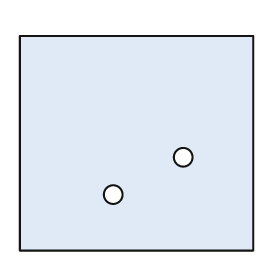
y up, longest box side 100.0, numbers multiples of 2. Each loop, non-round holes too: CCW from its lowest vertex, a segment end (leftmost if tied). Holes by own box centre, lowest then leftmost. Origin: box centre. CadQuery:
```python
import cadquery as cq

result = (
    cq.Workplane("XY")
    .moveTo(-50.0, -46.0)
    .lineTo(50.0, -46.0)
    .lineTo(50.0, 46.0)
    .lineTo(-50.0, 46.0)
    .close()
    .moveTo(-10.0, -22.0)
    .circle(4.0)
    .moveTo(20.0, -6.0)
    .circle(4.0)
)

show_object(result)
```